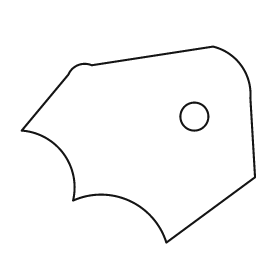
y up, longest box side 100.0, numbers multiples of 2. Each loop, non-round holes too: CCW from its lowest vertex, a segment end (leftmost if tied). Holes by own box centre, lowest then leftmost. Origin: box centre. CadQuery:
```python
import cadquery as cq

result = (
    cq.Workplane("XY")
    .moveTo(12.0, -42.0)
    .lineTo(50.0, -14.0)
    .lineTo(48.0, 20.0)
    .threePointArc((44.0, 34.0), (32.0, 42.0))
    .lineTo(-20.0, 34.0)
    .threePointArc((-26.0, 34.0), (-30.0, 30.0))
    .lineTo(-50.0, 6.0)
    .threePointArc((-32.0, -4.0), (-28.0, -24.0))
    .threePointArc((-4.0, -24.0), (12.0, -42.0))
    .close()
    .moveTo(24.0, 12.0)
    .circle(6.0)
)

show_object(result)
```